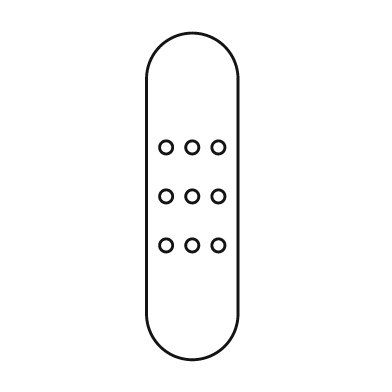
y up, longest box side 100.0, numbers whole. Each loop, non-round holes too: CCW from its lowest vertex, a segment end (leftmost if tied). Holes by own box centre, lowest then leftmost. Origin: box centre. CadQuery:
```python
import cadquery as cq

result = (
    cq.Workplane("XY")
    .moveTo(-14.0, -36.0)
    .threePointArc((0.0, -50.0), (14.0, -36.0))
    .lineTo(14.0, 36.0)
    .threePointArc((0.0, 50.0), (-14.0, 36.0))
    .close()
    .moveTo(-8.0, -15.0)
    .circle(2.0)
    .moveTo(0.0, -15.0)
    .circle(2.0)
    .moveTo(8.0, -15.0)
    .circle(2.0)
    .moveTo(-8.0, 0.0)
    .circle(2.0)
    .moveTo(0.0, 0.0)
    .circle(2.0)
    .moveTo(8.0, 0.0)
    .circle(2.0)
    .moveTo(-8.0, 15.0)
    .circle(2.0)
    .moveTo(0.0, 15.0)
    .circle(2.0)
    .moveTo(8.0, 15.0)
    .circle(2.0)
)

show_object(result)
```